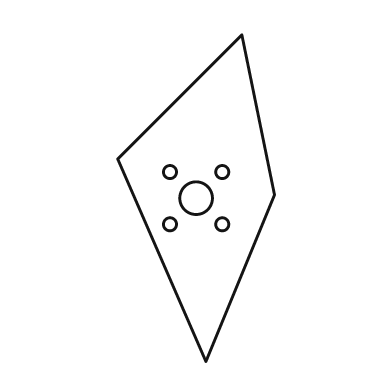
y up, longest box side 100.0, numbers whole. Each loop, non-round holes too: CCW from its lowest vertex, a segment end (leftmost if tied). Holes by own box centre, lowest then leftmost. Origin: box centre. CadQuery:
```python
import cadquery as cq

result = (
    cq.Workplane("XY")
    .moveTo(3.0, -50.0)
    .lineTo(24.0, 1.0)
    .lineTo(14.0, 50.0)
    .lineTo(-24.0, 12.0)
    .close()
    .moveTo(-8.0, -8.0)
    .circle(2.0)
    .moveTo(8.0, -8.0)
    .circle(2.0)
    .moveTo(0.0, 0.0)
    .circle(5.0)
    .moveTo(-8.0, 8.0)
    .circle(2.0)
    .moveTo(8.0, 8.0)
    .circle(2.0)
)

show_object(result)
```